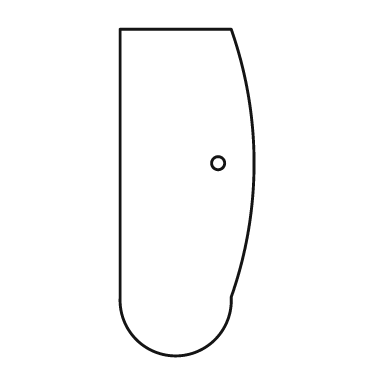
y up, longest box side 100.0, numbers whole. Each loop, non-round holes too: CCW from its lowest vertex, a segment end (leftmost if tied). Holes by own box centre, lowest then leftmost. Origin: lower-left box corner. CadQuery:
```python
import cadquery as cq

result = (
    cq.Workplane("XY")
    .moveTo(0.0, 18.0)
    .threePointArc((17.0, 0.0), (34.0, 18.0))
    .threePointArc((41.0, 59.0), (34.0, 100.0))
    .lineTo(0.0, 100.0)
    .close()
    .moveTo(30.0, 59.0)
    .circle(2.0)
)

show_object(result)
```